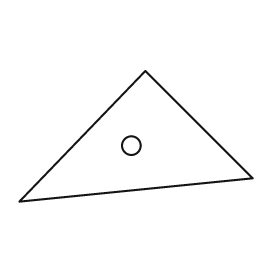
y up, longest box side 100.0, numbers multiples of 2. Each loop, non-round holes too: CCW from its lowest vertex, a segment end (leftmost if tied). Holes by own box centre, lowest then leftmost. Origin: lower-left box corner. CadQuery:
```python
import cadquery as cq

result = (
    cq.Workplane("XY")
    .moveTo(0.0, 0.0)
    .lineTo(100.0, 10.0)
    .lineTo(54.0, 56.0)
    .close()
    .moveTo(48.0, 24.0)
    .circle(4.0)
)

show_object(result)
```